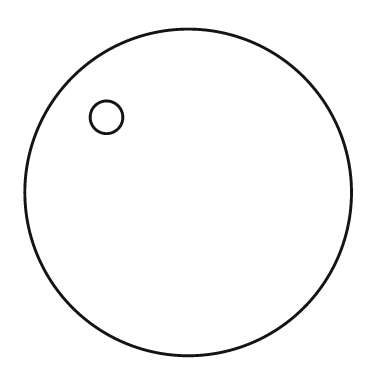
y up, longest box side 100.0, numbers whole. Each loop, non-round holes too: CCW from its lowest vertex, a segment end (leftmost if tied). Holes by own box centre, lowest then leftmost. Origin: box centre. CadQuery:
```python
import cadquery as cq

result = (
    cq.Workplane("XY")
    .moveTo(0.0, 0.0)
    .circle(50.0)
    .moveTo(-25.0, 23.0)
    .circle(5.0)
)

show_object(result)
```